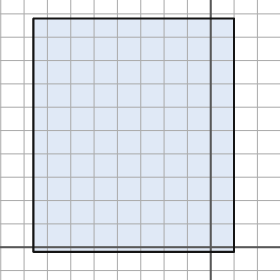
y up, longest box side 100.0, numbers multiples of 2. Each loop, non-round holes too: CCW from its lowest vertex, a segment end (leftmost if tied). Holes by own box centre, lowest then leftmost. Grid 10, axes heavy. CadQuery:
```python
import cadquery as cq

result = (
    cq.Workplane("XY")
    .moveTo(-76.0, -2.0)
    .lineTo(10.0, -2.0)
    .lineTo(10.0, 98.0)
    .lineTo(-76.0, 98.0)
    .close()
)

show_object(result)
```